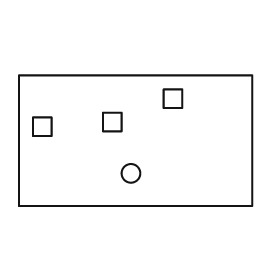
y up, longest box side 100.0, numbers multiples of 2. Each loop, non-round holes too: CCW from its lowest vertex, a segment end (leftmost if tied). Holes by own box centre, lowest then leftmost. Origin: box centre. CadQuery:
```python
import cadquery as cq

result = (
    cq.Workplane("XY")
    .moveTo(-50.0, -28.0)
    .lineTo(50.0, -28.0)
    .lineTo(50.0, 28.0)
    .lineTo(-50.0, 28.0)
    .close()
    .moveTo(-2.0, -14.0)
    .circle(4.0)
    .moveTo(-44.0, 2.0)
    .lineTo(-36.0, 2.0)
    .lineTo(-36.0, 10.0)
    .lineTo(-44.0, 10.0)
    .close()
    .moveTo(-14.0, 4.0)
    .lineTo(-6.0, 4.0)
    .lineTo(-6.0, 12.0)
    .lineTo(-14.0, 12.0)
    .close()
    .moveTo(12.0, 14.0)
    .lineTo(20.0, 14.0)
    .lineTo(20.0, 22.0)
    .lineTo(12.0, 22.0)
    .close()
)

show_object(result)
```